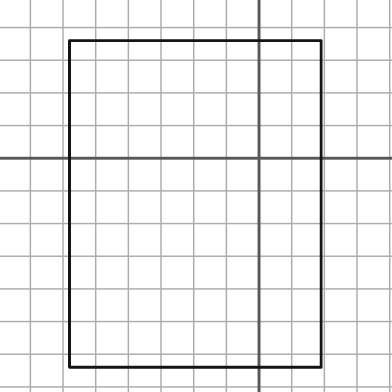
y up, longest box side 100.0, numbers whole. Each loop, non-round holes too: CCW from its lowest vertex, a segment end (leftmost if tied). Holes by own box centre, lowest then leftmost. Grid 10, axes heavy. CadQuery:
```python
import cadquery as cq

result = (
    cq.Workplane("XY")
    .moveTo(-58.0, -64.0)
    .lineTo(19.0, -64.0)
    .lineTo(19.0, 36.0)
    .lineTo(-58.0, 36.0)
    .close()
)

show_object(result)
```